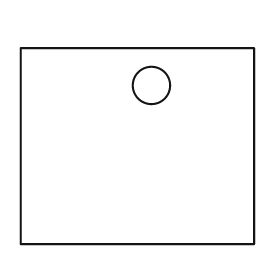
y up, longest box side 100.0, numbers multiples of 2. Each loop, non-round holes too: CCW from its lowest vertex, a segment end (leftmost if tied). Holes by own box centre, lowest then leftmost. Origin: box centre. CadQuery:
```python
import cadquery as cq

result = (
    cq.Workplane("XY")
    .moveTo(-50.0, -42.0)
    .lineTo(50.0, -42.0)
    .lineTo(50.0, 42.0)
    .lineTo(-50.0, 42.0)
    .close()
    .moveTo(6.0, 26.0)
    .circle(8.0)
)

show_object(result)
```